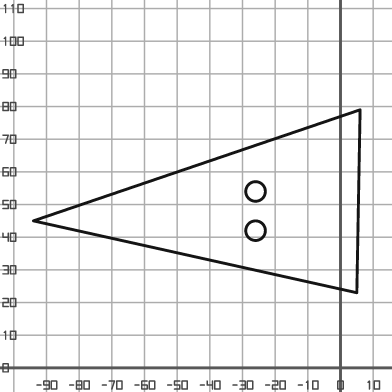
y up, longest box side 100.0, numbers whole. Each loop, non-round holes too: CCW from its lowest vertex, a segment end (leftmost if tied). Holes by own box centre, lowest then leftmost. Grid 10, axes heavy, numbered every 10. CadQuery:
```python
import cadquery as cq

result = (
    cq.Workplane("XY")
    .moveTo(5.0, 23.0)
    .lineTo(6.0, 79.0)
    .lineTo(-94.0, 45.0)
    .close()
    .moveTo(-26.0, 42.0)
    .circle(3.0)
    .moveTo(-26.0, 54.0)
    .circle(3.0)
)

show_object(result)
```